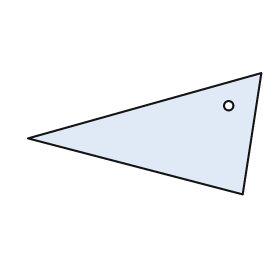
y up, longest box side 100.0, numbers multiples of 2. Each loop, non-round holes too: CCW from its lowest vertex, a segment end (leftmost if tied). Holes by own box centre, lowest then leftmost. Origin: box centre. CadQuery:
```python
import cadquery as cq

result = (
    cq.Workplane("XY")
    .moveTo(42.0, -26.0)
    .lineTo(50.0, 26.0)
    .lineTo(-50.0, -2.0)
    .close()
    .moveTo(36.0, 12.0)
    .circle(2.0)
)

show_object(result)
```